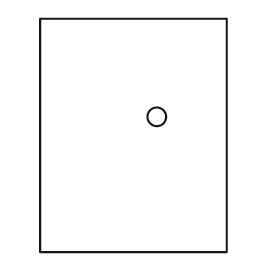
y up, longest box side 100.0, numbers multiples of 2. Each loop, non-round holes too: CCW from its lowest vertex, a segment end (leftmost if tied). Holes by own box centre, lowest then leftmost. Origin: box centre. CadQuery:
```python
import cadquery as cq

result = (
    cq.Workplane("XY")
    .moveTo(-40.0, -50.0)
    .lineTo(40.0, -50.0)
    .lineTo(40.0, 50.0)
    .lineTo(-40.0, 50.0)
    .close()
    .moveTo(10.0, 8.0)
    .circle(4.0)
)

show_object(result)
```